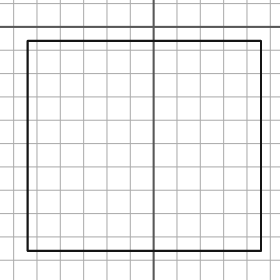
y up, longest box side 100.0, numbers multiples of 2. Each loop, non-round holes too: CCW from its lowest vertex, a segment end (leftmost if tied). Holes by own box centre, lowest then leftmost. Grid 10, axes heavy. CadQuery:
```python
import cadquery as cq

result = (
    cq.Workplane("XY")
    .moveTo(-54.0, -96.0)
    .lineTo(46.0, -96.0)
    .lineTo(46.0, -6.0)
    .lineTo(-54.0, -6.0)
    .close()
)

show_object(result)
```